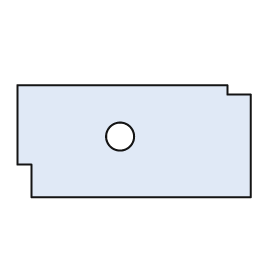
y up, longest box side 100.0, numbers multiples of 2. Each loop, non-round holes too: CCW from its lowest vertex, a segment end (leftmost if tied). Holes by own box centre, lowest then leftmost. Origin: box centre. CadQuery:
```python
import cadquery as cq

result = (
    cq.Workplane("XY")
    .moveTo(-44.0, -24.0)
    .lineTo(50.0, -24.0)
    .lineTo(50.0, 20.0)
    .lineTo(40.0, 20.0)
    .lineTo(40.0, 24.0)
    .lineTo(-50.0, 24.0)
    .lineTo(-50.0, -10.0)
    .lineTo(-44.0, -10.0)
    .close()
    .moveTo(-6.0, 2.0)
    .circle(6.0)
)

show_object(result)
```